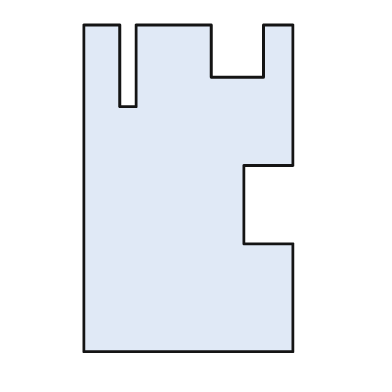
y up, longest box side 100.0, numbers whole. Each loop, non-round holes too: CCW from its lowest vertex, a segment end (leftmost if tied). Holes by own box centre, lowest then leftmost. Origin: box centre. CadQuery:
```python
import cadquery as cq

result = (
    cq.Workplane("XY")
    .moveTo(-32.0, -50.0)
    .lineTo(32.0, -50.0)
    .lineTo(32.0, -17.0)
    .lineTo(17.0, -17.0)
    .lineTo(17.0, 7.0)
    .lineTo(32.0, 7.0)
    .lineTo(32.0, 50.0)
    .lineTo(23.0, 50.0)
    .lineTo(23.0, 34.0)
    .lineTo(7.0, 34.0)
    .lineTo(7.0, 50.0)
    .lineTo(-16.0, 50.0)
    .lineTo(-16.0, 25.0)
    .lineTo(-21.0, 25.0)
    .lineTo(-21.0, 50.0)
    .lineTo(-32.0, 50.0)
    .close()
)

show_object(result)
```